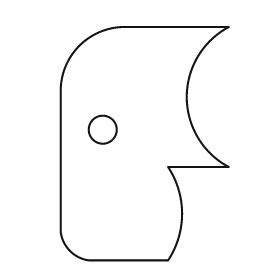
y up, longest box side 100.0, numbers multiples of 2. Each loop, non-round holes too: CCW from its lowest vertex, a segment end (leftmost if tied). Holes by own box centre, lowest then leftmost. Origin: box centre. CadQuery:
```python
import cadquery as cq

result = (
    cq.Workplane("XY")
    .moveTo(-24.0, -50.0)
    .lineTo(10.0, -50.0)
    .threePointArc((16.0, -30.0), (10.0, -10.0))
    .lineTo(36.0, -10.0)
    .threePointArc((18.0, 20.0), (36.0, 50.0))
    .lineTo(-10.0, 50.0)
    .threePointArc((-28.0, 42.0), (-36.0, 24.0))
    .lineTo(-36.0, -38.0)
    .threePointArc((-32.0, -46.0), (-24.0, -50.0))
    .close()
    .moveTo(-18.0, 6.0)
    .circle(6.0)
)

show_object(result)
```